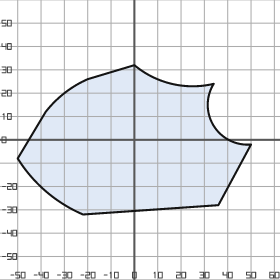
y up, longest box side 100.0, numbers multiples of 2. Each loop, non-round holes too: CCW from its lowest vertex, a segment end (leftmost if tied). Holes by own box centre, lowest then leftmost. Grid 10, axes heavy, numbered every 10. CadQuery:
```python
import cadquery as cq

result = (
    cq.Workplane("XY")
    .moveTo(-22.0, -32.0)
    .lineTo(36.0, -28.0)
    .lineTo(50.0, -2.0)
    .threePointArc((34.0, 6.0), (34.0, 24.0))
    .threePointArc((16.0, 24.0), (0.0, 32.0))
    .lineTo(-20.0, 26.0)
    .threePointArc((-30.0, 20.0), (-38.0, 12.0))
    .lineTo(-50.0, -8.0)
    .threePointArc((-38.0, -22.0), (-22.0, -32.0))
    .close()
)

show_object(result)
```